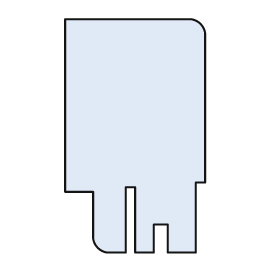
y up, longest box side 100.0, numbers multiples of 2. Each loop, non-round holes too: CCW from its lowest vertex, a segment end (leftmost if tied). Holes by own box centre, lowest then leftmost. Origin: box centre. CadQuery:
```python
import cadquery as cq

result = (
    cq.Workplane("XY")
    .moveTo(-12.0, -50.0)
    .lineTo(-4.0, -50.0)
    .lineTo(-4.0, -22.0)
    .lineTo(0.0, -22.0)
    .lineTo(0.0, -50.0)
    .lineTo(8.0, -50.0)
    .lineTo(8.0, -38.0)
    .lineTo(14.0, -38.0)
    .lineTo(14.0, -50.0)
    .lineTo(26.0, -50.0)
    .lineTo(26.0, -20.0)
    .lineTo(30.0, -20.0)
    .lineTo(30.0, 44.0)
    .threePointArc((28.0, 48.0), (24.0, 50.0))
    .lineTo(-30.0, 50.0)
    .lineTo(-30.0, -24.0)
    .lineTo(-18.0, -24.0)
    .lineTo(-18.0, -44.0)
    .threePointArc((-16.0, -48.0), (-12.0, -50.0))
    .close()
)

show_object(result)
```